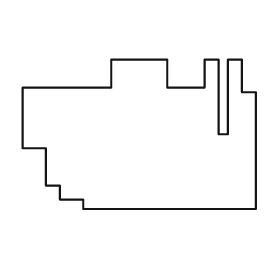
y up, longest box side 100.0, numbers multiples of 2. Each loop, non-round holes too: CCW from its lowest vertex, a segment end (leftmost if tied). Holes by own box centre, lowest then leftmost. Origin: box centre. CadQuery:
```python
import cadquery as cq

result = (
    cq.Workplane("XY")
    .moveTo(-24.0, -32.0)
    .lineTo(50.0, -32.0)
    .lineTo(50.0, 18.0)
    .lineTo(44.0, 18.0)
    .lineTo(44.0, 32.0)
    .lineTo(38.0, 32.0)
    .lineTo(38.0, 0.0)
    .lineTo(34.0, 0.0)
    .lineTo(34.0, 32.0)
    .lineTo(28.0, 32.0)
    .lineTo(28.0, 20.0)
    .lineTo(12.0, 20.0)
    .lineTo(12.0, 32.0)
    .lineTo(-12.0, 32.0)
    .lineTo(-12.0, 20.0)
    .lineTo(-50.0, 20.0)
    .lineTo(-50.0, -6.0)
    .lineTo(-40.0, -6.0)
    .lineTo(-40.0, -22.0)
    .lineTo(-34.0, -22.0)
    .lineTo(-34.0, -28.0)
    .lineTo(-24.0, -28.0)
    .close()
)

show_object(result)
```